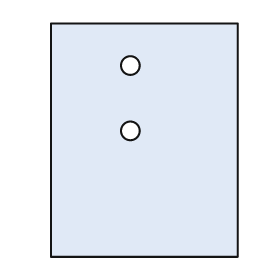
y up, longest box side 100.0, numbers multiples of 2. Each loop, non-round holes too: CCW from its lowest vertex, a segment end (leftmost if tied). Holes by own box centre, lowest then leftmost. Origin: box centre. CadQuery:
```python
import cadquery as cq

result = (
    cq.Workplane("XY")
    .moveTo(-40.0, -50.0)
    .lineTo(40.0, -50.0)
    .lineTo(40.0, 50.0)
    .lineTo(-40.0, 50.0)
    .close()
    .moveTo(-6.0, 4.0)
    .circle(4.0)
    .moveTo(-6.0, 32.0)
    .circle(4.0)
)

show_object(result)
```